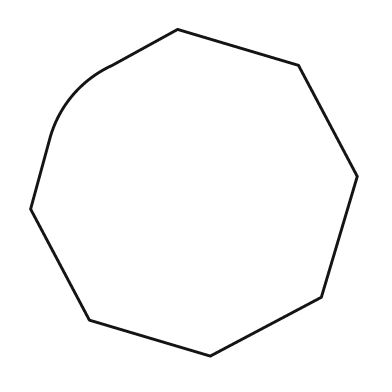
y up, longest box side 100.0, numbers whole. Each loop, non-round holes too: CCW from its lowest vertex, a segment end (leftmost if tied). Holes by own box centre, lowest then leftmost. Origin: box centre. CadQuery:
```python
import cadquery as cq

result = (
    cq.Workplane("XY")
    .moveTo(5.0, -50.0)
    .lineTo(39.0, -32.0)
    .lineTo(50.0, 5.0)
    .lineTo(32.0, 39.0)
    .lineTo(-5.0, 50.0)
    .lineTo(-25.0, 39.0)
    .threePointArc((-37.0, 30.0), (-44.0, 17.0))
    .lineTo(-50.0, -5.0)
    .lineTo(-32.0, -39.0)
    .close()
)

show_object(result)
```